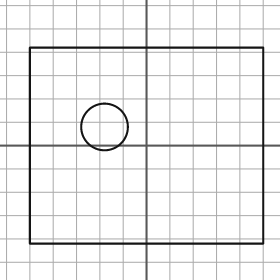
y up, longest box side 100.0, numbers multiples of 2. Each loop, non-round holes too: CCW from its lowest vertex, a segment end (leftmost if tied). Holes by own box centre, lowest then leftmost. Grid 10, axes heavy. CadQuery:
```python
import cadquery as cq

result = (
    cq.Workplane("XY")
    .moveTo(-50.0, -42.0)
    .lineTo(50.0, -42.0)
    .lineTo(50.0, 42.0)
    .lineTo(-50.0, 42.0)
    .close()
    .moveTo(-18.0, 8.0)
    .circle(10.0)
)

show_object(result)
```